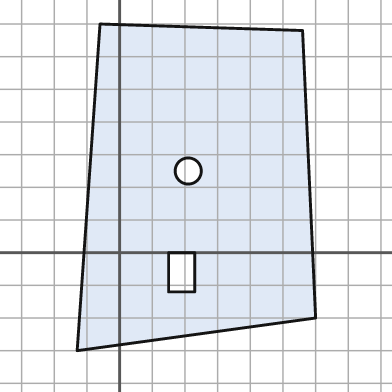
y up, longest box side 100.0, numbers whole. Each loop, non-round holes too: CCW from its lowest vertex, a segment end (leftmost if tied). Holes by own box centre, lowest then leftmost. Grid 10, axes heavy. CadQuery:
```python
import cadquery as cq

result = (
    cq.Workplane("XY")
    .moveTo(-13.0, -30.0)
    .lineTo(60.0, -20.0)
    .lineTo(56.0, 68.0)
    .lineTo(-6.0, 70.0)
    .close()
    .moveTo(15.0, -12.0)
    .lineTo(23.0, -12.0)
    .lineTo(23.0, 0.0)
    .lineTo(15.0, 0.0)
    .close()
    .moveTo(21.0, 25.0)
    .circle(4.0)
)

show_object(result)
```